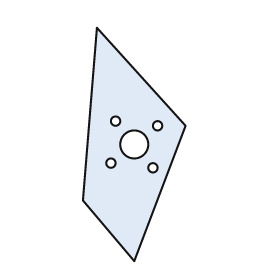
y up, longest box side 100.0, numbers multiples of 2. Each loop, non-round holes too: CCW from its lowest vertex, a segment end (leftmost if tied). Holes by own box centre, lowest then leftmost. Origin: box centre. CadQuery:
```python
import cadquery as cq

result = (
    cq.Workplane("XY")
    .moveTo(0.0, -50.0)
    .lineTo(22.0, 8.0)
    .lineTo(-16.0, 50.0)
    .lineTo(-22.0, -24.0)
    .close()
    .moveTo(8.0, -10.0)
    .circle(2.0)
    .moveTo(-10.0, -8.0)
    .circle(2.0)
    .moveTo(0.0, 0.0)
    .circle(6.0)
    .moveTo(10.0, 8.0)
    .circle(2.0)
    .moveTo(-8.0, 10.0)
    .circle(2.0)
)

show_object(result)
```